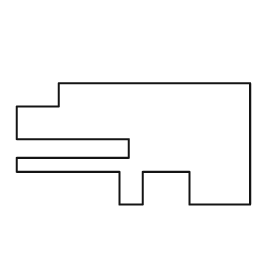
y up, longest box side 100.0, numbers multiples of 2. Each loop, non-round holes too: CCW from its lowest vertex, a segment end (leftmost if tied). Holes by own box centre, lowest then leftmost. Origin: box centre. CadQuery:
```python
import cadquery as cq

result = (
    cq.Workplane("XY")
    .moveTo(-6.0, -26.0)
    .lineTo(4.0, -26.0)
    .lineTo(4.0, -12.0)
    .lineTo(24.0, -12.0)
    .lineTo(24.0, -26.0)
    .lineTo(50.0, -26.0)
    .lineTo(50.0, 26.0)
    .lineTo(-32.0, 26.0)
    .lineTo(-32.0, 16.0)
    .lineTo(-50.0, 16.0)
    .lineTo(-50.0, 2.0)
    .lineTo(-2.0, 2.0)
    .lineTo(-2.0, -6.0)
    .lineTo(-50.0, -6.0)
    .lineTo(-50.0, -12.0)
    .lineTo(-6.0, -12.0)
    .close()
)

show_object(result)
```